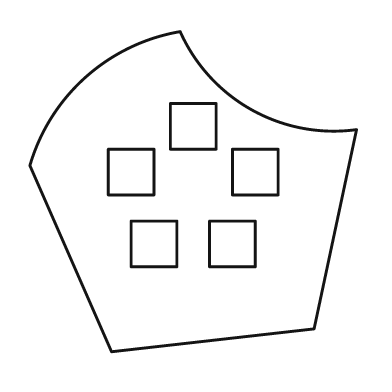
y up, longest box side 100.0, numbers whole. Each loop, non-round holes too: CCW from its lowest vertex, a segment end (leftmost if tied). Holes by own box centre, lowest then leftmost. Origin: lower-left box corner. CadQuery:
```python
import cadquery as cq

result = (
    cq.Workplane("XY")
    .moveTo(25.0, 0.0)
    .lineTo(87.0, 7.0)
    .lineTo(100.0, 68.0)
    .threePointArc((68.0, 74.0), (46.0, 98.0))
    .threePointArc((17.0, 84.0), (0.0, 57.0))
    .close()
    .moveTo(31.0, 26.0)
    .lineTo(45.0, 26.0)
    .lineTo(45.0, 40.0)
    .lineTo(31.0, 40.0)
    .close()
    .moveTo(55.0, 26.0)
    .lineTo(69.0, 26.0)
    .lineTo(69.0, 40.0)
    .lineTo(55.0, 40.0)
    .close()
    .moveTo(24.0, 48.0)
    .lineTo(38.0, 48.0)
    .lineTo(38.0, 62.0)
    .lineTo(24.0, 62.0)
    .close()
    .moveTo(62.0, 48.0)
    .lineTo(76.0, 48.0)
    .lineTo(76.0, 62.0)
    .lineTo(62.0, 62.0)
    .close()
    .moveTo(43.0, 62.0)
    .lineTo(57.0, 62.0)
    .lineTo(57.0, 76.0)
    .lineTo(43.0, 76.0)
    .close()
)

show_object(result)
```